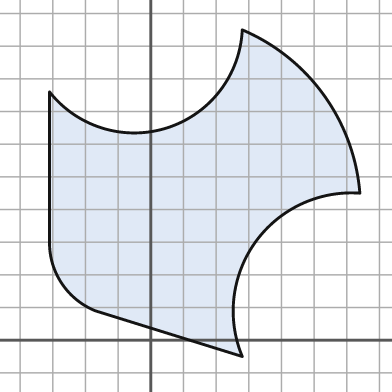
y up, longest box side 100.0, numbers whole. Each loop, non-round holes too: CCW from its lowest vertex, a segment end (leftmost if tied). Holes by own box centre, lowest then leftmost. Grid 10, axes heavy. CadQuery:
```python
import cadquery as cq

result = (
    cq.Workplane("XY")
    .moveTo(28.0, -5.0)
    .threePointArc((32.0, 30.0), (64.0, 45.0))
    .threePointArc((53.0, 75.0), (28.0, 95.0))
    .threePointArc((5.0, 65.0), (-31.0, 76.0))
    .lineTo(-31.0, 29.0)
    .threePointArc((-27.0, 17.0), (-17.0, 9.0))
    .close()
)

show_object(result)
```